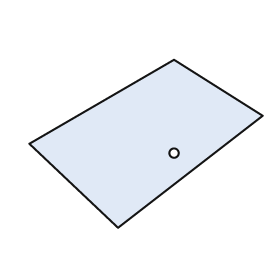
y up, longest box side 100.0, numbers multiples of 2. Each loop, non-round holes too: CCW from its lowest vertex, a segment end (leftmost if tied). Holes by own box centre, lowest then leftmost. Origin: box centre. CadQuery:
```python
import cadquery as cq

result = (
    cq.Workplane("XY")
    .moveTo(-12.0, -36.0)
    .lineTo(50.0, 12.0)
    .lineTo(12.0, 36.0)
    .lineTo(-50.0, 0.0)
    .close()
    .moveTo(12.0, -4.0)
    .circle(2.0)
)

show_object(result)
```